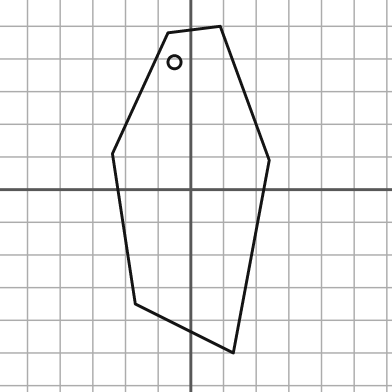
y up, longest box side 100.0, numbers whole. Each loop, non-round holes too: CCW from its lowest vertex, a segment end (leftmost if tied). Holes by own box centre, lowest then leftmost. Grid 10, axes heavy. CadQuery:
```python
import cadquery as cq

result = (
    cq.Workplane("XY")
    .moveTo(13.0, -50.0)
    .lineTo(24.0, 9.0)
    .lineTo(9.0, 50.0)
    .lineTo(-7.0, 48.0)
    .lineTo(-24.0, 11.0)
    .lineTo(-17.0, -35.0)
    .close()
    .moveTo(-5.0, 39.0)
    .circle(2.0)
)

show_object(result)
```